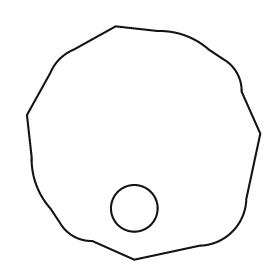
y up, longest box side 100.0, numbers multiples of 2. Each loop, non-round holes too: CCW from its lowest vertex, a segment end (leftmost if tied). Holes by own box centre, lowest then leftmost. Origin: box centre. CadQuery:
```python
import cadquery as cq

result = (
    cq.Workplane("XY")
    .moveTo(-4.0, -50.0)
    .lineTo(24.0, -44.0)
    .threePointArc((38.0, -38.0), (44.0, -24.0))
    .lineTo(50.0, 4.0)
    .lineTo(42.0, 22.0)
    .threePointArc((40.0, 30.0), (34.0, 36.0))
    .lineTo(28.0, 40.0)
    .threePointArc((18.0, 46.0), (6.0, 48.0))
    .lineTo(-12.0, 50.0)
    .lineTo(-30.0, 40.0)
    .threePointArc((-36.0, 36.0), (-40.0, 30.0))
    .lineTo(-50.0, 12.0)
    .lineTo(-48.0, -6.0)
    .threePointArc((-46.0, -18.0), (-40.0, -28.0))
    .lineTo(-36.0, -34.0)
    .threePointArc((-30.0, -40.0), (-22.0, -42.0))
    .close()
    .moveTo(-4.0, -28.0)
    .circle(10.0)
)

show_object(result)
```